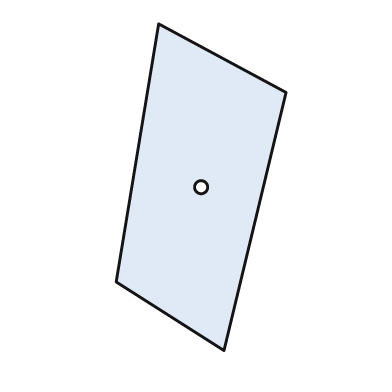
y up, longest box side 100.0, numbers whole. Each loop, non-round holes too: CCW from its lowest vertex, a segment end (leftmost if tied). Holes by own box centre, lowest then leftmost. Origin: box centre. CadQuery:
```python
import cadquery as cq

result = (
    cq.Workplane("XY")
    .moveTo(7.0, -50.0)
    .lineTo(26.0, 29.0)
    .lineTo(-13.0, 50.0)
    .lineTo(-26.0, -29.0)
    .close()
    .moveTo(0.0, 0.0)
    .circle(2.0)
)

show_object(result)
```